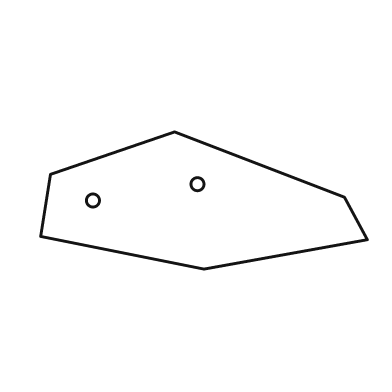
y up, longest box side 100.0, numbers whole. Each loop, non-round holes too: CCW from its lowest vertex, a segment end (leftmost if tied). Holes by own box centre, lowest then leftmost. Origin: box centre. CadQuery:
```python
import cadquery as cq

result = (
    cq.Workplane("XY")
    .moveTo(0.0, -21.0)
    .lineTo(50.0, -12.0)
    .lineTo(43.0, 1.0)
    .lineTo(-9.0, 21.0)
    .lineTo(-47.0, 8.0)
    .lineTo(-50.0, -11.0)
    .close()
    .moveTo(-34.0, 0.0)
    .circle(2.0)
    .moveTo(-2.0, 5.0)
    .circle(2.0)
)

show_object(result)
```